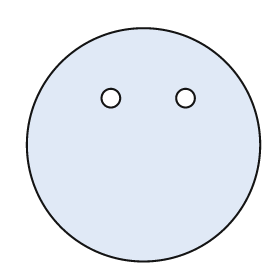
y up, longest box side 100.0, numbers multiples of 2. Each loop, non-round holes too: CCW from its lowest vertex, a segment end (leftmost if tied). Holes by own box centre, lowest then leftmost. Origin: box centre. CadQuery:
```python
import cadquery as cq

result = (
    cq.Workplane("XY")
    .moveTo(0.0, 0.0)
    .circle(50.0)
    .moveTo(-14.0, 20.0)
    .circle(4.0)
    .moveTo(18.0, 20.0)
    .circle(4.0)
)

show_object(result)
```